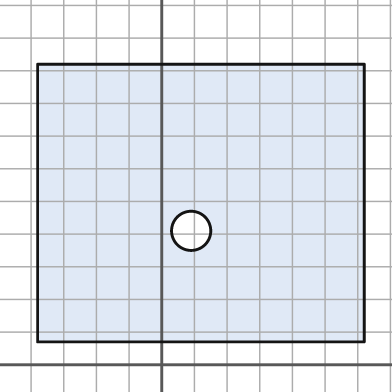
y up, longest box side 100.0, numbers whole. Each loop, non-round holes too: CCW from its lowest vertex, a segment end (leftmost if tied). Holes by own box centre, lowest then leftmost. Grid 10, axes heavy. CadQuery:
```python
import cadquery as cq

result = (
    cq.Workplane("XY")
    .moveTo(-38.0, 7.0)
    .lineTo(62.0, 7.0)
    .lineTo(62.0, 92.0)
    .lineTo(-38.0, 92.0)
    .close()
    .moveTo(9.0, 41.0)
    .circle(6.0)
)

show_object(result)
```